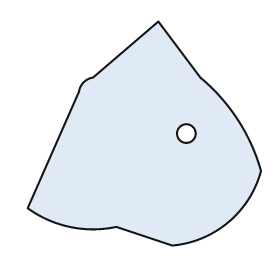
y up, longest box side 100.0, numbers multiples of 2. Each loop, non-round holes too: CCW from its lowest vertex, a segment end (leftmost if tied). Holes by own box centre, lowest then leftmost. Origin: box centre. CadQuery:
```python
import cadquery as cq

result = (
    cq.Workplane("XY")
    .moveTo(12.0, -48.0)
    .threePointArc((36.0, -38.0), (50.0, -16.0))
    .threePointArc((40.0, 6.0), (24.0, 24.0))
    .lineTo(6.0, 48.0)
    .lineTo(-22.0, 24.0)
    .threePointArc((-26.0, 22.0), (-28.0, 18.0))
    .lineTo(-50.0, -32.0)
    .threePointArc((-32.0, -40.0), (-12.0, -40.0))
    .close()
    .moveTo(18.0, 0.0)
    .circle(4.0)
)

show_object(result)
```